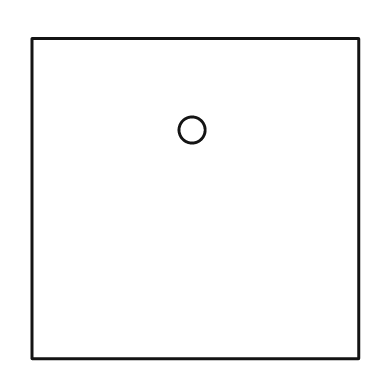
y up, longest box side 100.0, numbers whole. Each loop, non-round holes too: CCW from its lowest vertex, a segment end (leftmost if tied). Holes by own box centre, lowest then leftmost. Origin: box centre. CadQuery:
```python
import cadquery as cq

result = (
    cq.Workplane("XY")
    .moveTo(-50.0, -49.0)
    .lineTo(50.0, -49.0)
    .lineTo(50.0, 49.0)
    .lineTo(-50.0, 49.0)
    .close()
    .moveTo(-1.0, 21.0)
    .circle(4.0)
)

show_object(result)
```